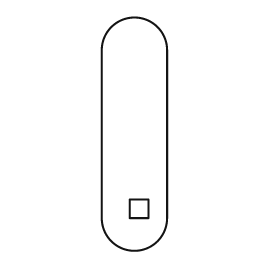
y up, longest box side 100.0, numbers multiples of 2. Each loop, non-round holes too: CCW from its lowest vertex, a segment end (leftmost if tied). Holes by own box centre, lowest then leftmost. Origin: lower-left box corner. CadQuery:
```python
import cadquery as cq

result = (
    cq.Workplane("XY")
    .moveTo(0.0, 14.0)
    .threePointArc((14.0, 0.0), (28.0, 14.0))
    .lineTo(28.0, 86.0)
    .threePointArc((14.0, 100.0), (0.0, 86.0))
    .close()
    .moveTo(12.0, 14.0)
    .lineTo(20.0, 14.0)
    .lineTo(20.0, 22.0)
    .lineTo(12.0, 22.0)
    .close()
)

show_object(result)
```